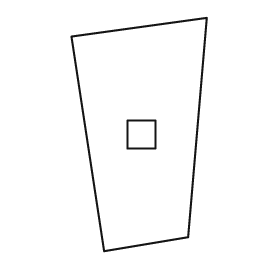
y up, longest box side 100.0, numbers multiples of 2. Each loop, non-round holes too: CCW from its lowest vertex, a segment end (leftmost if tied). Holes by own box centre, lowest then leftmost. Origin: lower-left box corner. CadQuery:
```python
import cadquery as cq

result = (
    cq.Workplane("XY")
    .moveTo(14.0, 0.0)
    .lineTo(50.0, 6.0)
    .lineTo(58.0, 100.0)
    .lineTo(0.0, 92.0)
    .close()
    .moveTo(24.0, 44.0)
    .lineTo(36.0, 44.0)
    .lineTo(36.0, 56.0)
    .lineTo(24.0, 56.0)
    .close()
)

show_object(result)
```